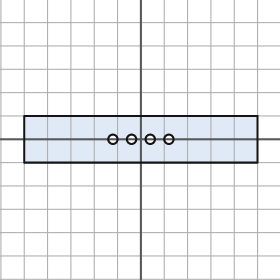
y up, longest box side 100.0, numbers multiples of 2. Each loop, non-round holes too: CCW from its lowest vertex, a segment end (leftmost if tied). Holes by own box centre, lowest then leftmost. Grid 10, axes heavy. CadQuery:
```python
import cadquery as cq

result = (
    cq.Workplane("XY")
    .moveTo(-50.0, -10.0)
    .lineTo(50.0, -10.0)
    .lineTo(50.0, 10.0)
    .lineTo(-50.0, 10.0)
    .close()
    .moveTo(-12.0, 0.0)
    .circle(2.0)
    .moveTo(-4.0, 0.0)
    .circle(2.0)
    .moveTo(4.0, 0.0)
    .circle(2.0)
    .moveTo(12.0, 0.0)
    .circle(2.0)
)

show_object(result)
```